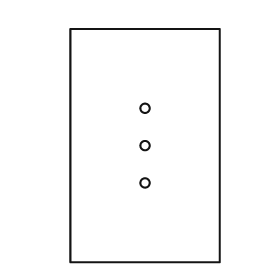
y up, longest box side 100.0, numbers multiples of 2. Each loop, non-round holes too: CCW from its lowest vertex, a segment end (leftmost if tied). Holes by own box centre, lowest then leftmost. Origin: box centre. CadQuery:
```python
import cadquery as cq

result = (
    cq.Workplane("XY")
    .moveTo(-32.0, -50.0)
    .lineTo(32.0, -50.0)
    .lineTo(32.0, 50.0)
    .lineTo(-32.0, 50.0)
    .close()
    .moveTo(0.0, -16.0)
    .circle(2.0)
    .moveTo(0.0, 0.0)
    .circle(2.0)
    .moveTo(0.0, 16.0)
    .circle(2.0)
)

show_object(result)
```